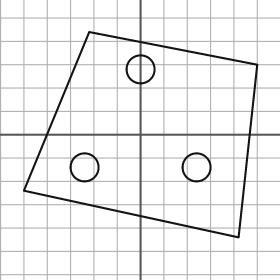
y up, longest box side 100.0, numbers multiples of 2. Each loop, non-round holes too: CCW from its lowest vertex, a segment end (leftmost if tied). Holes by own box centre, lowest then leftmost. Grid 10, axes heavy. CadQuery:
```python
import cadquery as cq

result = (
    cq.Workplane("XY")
    .moveTo(42.0, -44.0)
    .lineTo(50.0, 30.0)
    .lineTo(-22.0, 44.0)
    .lineTo(-50.0, -24.0)
    .close()
    .moveTo(-24.0, -14.0)
    .circle(6.0)
    .moveTo(24.0, -14.0)
    .circle(6.0)
    .moveTo(0.0, 28.0)
    .circle(6.0)
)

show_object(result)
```